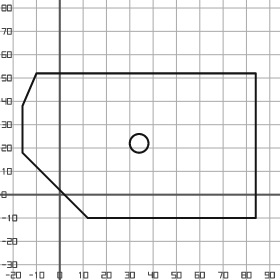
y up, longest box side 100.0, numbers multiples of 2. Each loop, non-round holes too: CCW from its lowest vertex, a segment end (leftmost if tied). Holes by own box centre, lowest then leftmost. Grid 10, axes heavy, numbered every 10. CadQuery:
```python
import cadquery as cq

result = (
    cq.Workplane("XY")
    .moveTo(12.0, -10.0)
    .lineTo(84.0, -10.0)
    .lineTo(84.0, 52.0)
    .lineTo(-10.0, 52.0)
    .lineTo(-16.0, 38.0)
    .lineTo(-16.0, 18.0)
    .close()
    .moveTo(34.0, 22.0)
    .circle(4.0)
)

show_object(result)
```